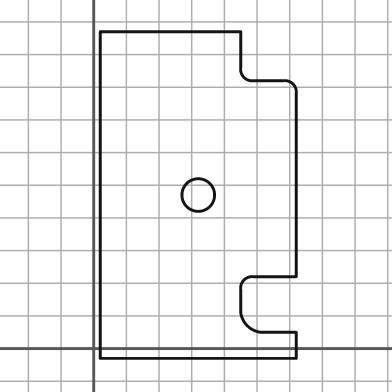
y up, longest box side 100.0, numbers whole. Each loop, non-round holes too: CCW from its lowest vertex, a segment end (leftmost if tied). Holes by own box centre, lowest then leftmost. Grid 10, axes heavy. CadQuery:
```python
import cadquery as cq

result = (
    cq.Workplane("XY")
    .moveTo(2.0, -3.0)
    .lineTo(62.0, -3.0)
    .lineTo(62.0, 5.0)
    .lineTo(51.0, 5.0)
    .threePointArc((47.0, 7.0), (45.0, 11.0))
    .lineTo(45.0, 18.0)
    .threePointArc((46.0, 21.0), (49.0, 22.0))
    .lineTo(62.0, 22.0)
    .lineTo(62.0, 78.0)
    .threePointArc((61.0, 81.0), (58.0, 82.0))
    .lineTo(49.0, 82.0)
    .threePointArc((46.0, 83.0), (45.0, 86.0))
    .lineTo(45.0, 97.0)
    .lineTo(2.0, 97.0)
    .close()
    .moveTo(32.0, 47.0)
    .circle(5.0)
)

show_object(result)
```